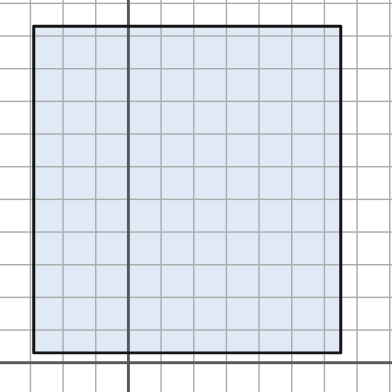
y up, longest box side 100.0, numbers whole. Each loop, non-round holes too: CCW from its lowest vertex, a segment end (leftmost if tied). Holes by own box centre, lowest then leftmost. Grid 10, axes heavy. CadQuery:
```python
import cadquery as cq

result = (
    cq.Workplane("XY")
    .moveTo(-29.0, 3.0)
    .lineTo(65.0, 3.0)
    .lineTo(65.0, 103.0)
    .lineTo(-29.0, 103.0)
    .close()
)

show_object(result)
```